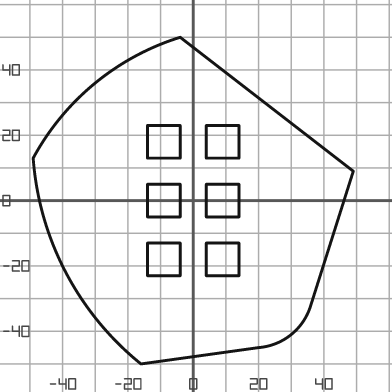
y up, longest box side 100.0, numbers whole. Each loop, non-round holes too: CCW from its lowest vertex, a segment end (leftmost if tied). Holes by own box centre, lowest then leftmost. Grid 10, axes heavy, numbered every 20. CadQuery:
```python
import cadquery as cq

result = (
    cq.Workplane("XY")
    .moveTo(-16.0, -50.0)
    .lineTo(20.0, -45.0)
    .threePointArc((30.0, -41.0), (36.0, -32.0))
    .lineTo(49.0, 9.0)
    .lineTo(-4.0, 50.0)
    .threePointArc((-30.0, 36.0), (-49.0, 13.0))
    .threePointArc((-39.0, -22.0), (-16.0, -50.0))
    .close()
    .moveTo(-14.0, -23.0)
    .lineTo(-4.0, -23.0)
    .lineTo(-4.0, -13.0)
    .lineTo(-14.0, -13.0)
    .close()
    .moveTo(4.0, -23.0)
    .lineTo(14.0, -23.0)
    .lineTo(14.0, -13.0)
    .lineTo(4.0, -13.0)
    .close()
    .moveTo(-14.0, -5.0)
    .lineTo(-4.0, -5.0)
    .lineTo(-4.0, 5.0)
    .lineTo(-14.0, 5.0)
    .close()
    .moveTo(4.0, -5.0)
    .lineTo(14.0, -5.0)
    .lineTo(14.0, 5.0)
    .lineTo(4.0, 5.0)
    .close()
    .moveTo(-14.0, 13.0)
    .lineTo(-4.0, 13.0)
    .lineTo(-4.0, 23.0)
    .lineTo(-14.0, 23.0)
    .close()
    .moveTo(4.0, 13.0)
    .lineTo(14.0, 13.0)
    .lineTo(14.0, 23.0)
    .lineTo(4.0, 23.0)
    .close()
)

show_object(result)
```